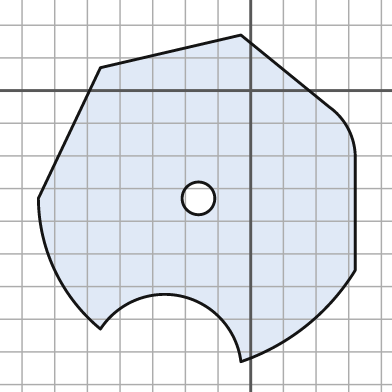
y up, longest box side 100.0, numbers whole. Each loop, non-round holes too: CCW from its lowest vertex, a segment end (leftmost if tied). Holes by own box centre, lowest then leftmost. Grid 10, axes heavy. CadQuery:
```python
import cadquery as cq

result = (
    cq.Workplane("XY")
    .moveTo(-3.0, -83.0)
    .threePointArc((17.0, -72.0), (32.0, -55.0))
    .lineTo(32.0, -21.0)
    .threePointArc((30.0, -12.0), (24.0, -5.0))
    .lineTo(-3.0, 17.0)
    .lineTo(-46.0, 7.0)
    .lineTo(-65.0, -33.0)
    .threePointArc((-60.0, -55.0), (-46.0, -73.0))
    .threePointArc((-21.0, -63.0), (-3.0, -83.0))
    .close()
    .moveTo(-16.0, -33.0)
    .circle(5.0)
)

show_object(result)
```